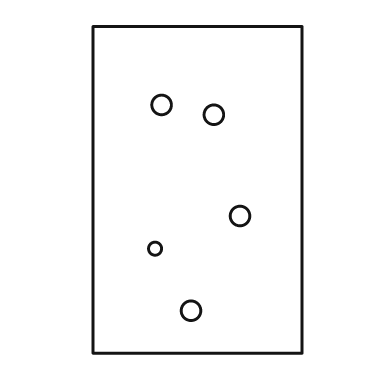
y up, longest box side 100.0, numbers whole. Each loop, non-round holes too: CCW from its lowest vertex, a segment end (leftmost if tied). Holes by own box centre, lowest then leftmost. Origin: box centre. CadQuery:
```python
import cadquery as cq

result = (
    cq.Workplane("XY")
    .moveTo(-32.0, -50.0)
    .lineTo(32.0, -50.0)
    .lineTo(32.0, 50.0)
    .lineTo(-32.0, 50.0)
    .close()
    .moveTo(-2.0, -37.0)
    .circle(3.0)
    .moveTo(-13.0, -18.0)
    .circle(2.0)
    .moveTo(13.0, -8.0)
    .circle(3.0)
    .moveTo(5.0, 23.0)
    .circle(3.0)
    .moveTo(-11.0, 26.0)
    .circle(3.0)
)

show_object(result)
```